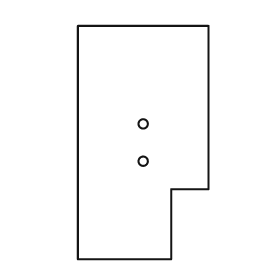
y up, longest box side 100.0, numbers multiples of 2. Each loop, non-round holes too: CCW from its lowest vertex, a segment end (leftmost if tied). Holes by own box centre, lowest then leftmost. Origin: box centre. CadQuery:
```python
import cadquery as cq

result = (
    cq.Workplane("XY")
    .moveTo(-28.0, -50.0)
    .lineTo(12.0, -50.0)
    .lineTo(12.0, -20.0)
    .lineTo(28.0, -20.0)
    .lineTo(28.0, 50.0)
    .lineTo(-28.0, 50.0)
    .close()
    .moveTo(0.0, -8.0)
    .circle(2.0)
    .moveTo(0.0, 8.0)
    .circle(2.0)
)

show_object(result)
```